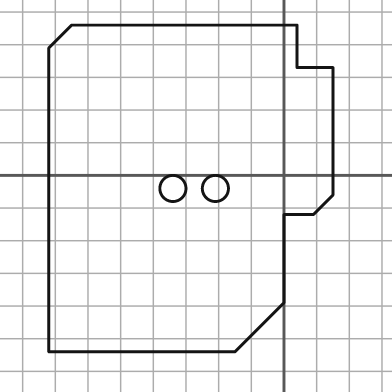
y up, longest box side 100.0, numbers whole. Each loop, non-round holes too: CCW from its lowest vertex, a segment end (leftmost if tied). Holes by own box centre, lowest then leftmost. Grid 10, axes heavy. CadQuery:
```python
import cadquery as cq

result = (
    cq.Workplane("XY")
    .moveTo(-72.0, -54.0)
    .lineTo(-15.0, -54.0)
    .lineTo(0.0, -39.0)
    .lineTo(0.0, -12.0)
    .lineTo(9.0, -12.0)
    .lineTo(15.0, -6.0)
    .lineTo(15.0, 33.0)
    .lineTo(4.0, 33.0)
    .lineTo(4.0, 46.0)
    .lineTo(-65.0, 46.0)
    .lineTo(-72.0, 39.0)
    .close()
    .moveTo(-34.0, -4.0)
    .circle(4.0)
    .moveTo(-21.0, -4.0)
    .circle(4.0)
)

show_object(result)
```